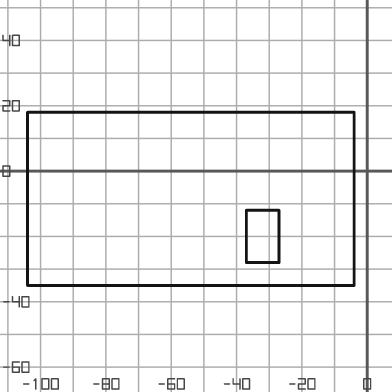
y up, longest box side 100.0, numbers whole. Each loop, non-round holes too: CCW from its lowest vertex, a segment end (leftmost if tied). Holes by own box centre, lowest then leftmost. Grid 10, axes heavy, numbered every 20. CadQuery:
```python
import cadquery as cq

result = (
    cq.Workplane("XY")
    .moveTo(-104.0, -35.0)
    .lineTo(-4.0, -35.0)
    .lineTo(-4.0, 18.0)
    .lineTo(-104.0, 18.0)
    .close()
    .moveTo(-37.0, -28.0)
    .lineTo(-27.0, -28.0)
    .lineTo(-27.0, -12.0)
    .lineTo(-37.0, -12.0)
    .close()
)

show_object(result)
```